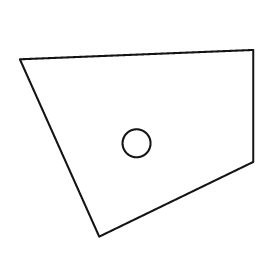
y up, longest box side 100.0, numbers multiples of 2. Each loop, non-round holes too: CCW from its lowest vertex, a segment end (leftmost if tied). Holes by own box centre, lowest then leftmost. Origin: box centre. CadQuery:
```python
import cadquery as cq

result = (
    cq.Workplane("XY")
    .moveTo(-16.0, -40.0)
    .lineTo(50.0, -8.0)
    .lineTo(50.0, 40.0)
    .lineTo(-50.0, 36.0)
    .close()
    .moveTo(0.0, 0.0)
    .circle(6.0)
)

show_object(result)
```